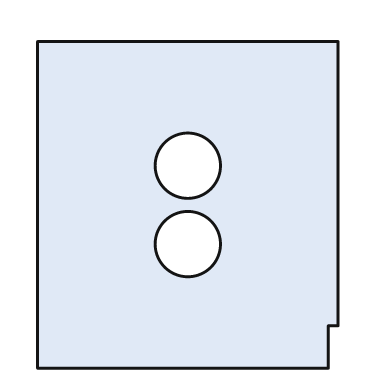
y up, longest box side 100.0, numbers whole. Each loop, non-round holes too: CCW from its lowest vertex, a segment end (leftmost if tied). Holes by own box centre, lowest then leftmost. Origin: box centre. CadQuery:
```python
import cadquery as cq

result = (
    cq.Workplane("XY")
    .moveTo(-46.0, -50.0)
    .lineTo(43.0, -50.0)
    .lineTo(43.0, -37.0)
    .lineTo(46.0, -37.0)
    .lineTo(46.0, 50.0)
    .lineTo(-46.0, 50.0)
    .close()
    .moveTo(0.0, -12.0)
    .circle(10.0)
    .moveTo(0.0, 12.0)
    .circle(10.0)
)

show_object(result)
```